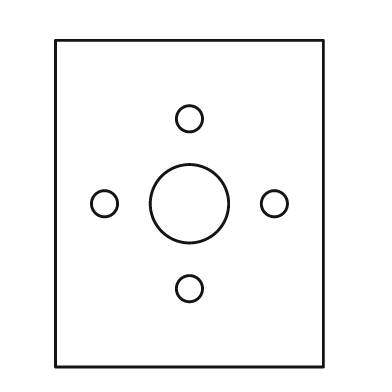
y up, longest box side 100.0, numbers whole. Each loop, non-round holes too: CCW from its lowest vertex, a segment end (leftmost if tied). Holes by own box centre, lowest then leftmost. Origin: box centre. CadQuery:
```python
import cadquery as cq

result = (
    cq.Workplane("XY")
    .moveTo(-41.0, -50.0)
    .lineTo(41.0, -50.0)
    .lineTo(41.0, 50.0)
    .lineTo(-41.0, 50.0)
    .close()
    .moveTo(0.0, -26.0)
    .circle(4.0)
    .moveTo(-26.0, 0.0)
    .circle(4.0)
    .moveTo(0.0, 0.0)
    .circle(12.0)
    .moveTo(26.0, 0.0)
    .circle(4.0)
    .moveTo(0.0, 26.0)
    .circle(4.0)
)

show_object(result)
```